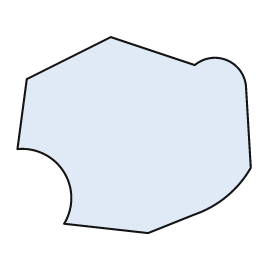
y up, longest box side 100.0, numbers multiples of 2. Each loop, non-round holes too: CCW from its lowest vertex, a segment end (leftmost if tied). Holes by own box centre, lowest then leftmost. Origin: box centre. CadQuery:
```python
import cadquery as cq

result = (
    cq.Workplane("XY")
    .moveTo(6.0, -42.0)
    .lineTo(26.0, -34.0)
    .threePointArc((40.0, -26.0), (50.0, -14.0))
    .lineTo(48.0, 20.0)
    .threePointArc((40.0, 32.0), (26.0, 30.0))
    .lineTo(-10.0, 42.0)
    .lineTo(-46.0, 24.0)
    .lineTo(-50.0, -6.0)
    .threePointArc((-30.0, -16.0), (-30.0, -38.0))
    .close()
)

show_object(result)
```